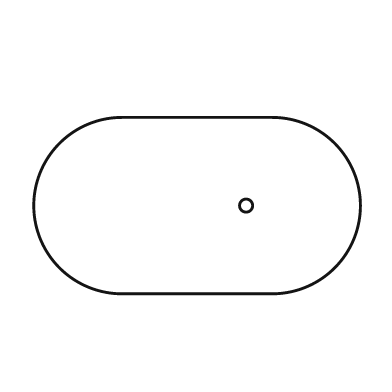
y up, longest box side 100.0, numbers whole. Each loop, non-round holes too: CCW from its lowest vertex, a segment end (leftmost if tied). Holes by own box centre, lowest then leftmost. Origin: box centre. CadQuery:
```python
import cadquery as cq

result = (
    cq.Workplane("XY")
    .moveTo(-23.0, -27.0)
    .lineTo(23.0, -27.0)
    .threePointArc((50.0, 0.0), (23.0, 27.0))
    .lineTo(-23.0, 27.0)
    .threePointArc((-50.0, 0.0), (-23.0, -27.0))
    .close()
    .moveTo(15.0, 0.0)
    .circle(2.0)
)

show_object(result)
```